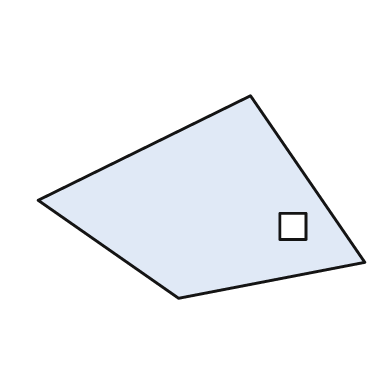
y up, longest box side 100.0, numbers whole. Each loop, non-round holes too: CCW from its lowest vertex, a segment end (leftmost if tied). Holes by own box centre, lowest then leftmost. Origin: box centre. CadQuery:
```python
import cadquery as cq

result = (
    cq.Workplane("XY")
    .moveTo(-7.0, -31.0)
    .lineTo(50.0, -20.0)
    .lineTo(15.0, 31.0)
    .lineTo(-50.0, -1.0)
    .close()
    .moveTo(24.0, -13.0)
    .lineTo(32.0, -13.0)
    .lineTo(32.0, -5.0)
    .lineTo(24.0, -5.0)
    .close()
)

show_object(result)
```